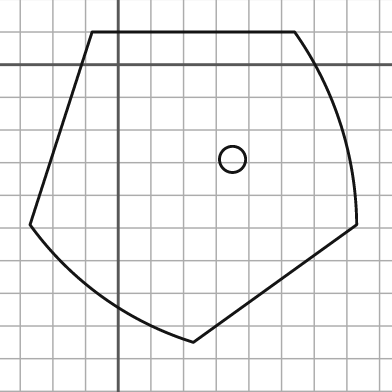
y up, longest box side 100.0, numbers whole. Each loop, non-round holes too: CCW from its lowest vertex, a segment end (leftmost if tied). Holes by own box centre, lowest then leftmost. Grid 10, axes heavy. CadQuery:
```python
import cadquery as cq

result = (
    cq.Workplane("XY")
    .moveTo(23.0, -85.0)
    .lineTo(73.0, -49.0)
    .threePointArc((68.0, -18.0), (54.0, 10.0))
    .lineTo(-8.0, 10.0)
    .lineTo(-27.0, -49.0)
    .threePointArc((-5.0, -71.0), (23.0, -85.0))
    .close()
    .moveTo(35.0, -29.0)
    .circle(4.0)
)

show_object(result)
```